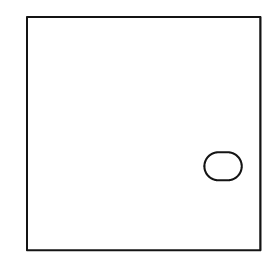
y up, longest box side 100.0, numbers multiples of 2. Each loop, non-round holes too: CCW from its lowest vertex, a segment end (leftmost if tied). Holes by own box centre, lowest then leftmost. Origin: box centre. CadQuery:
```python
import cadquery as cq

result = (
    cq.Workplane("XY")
    .moveTo(-50.0, -50.0)
    .lineTo(50.0, -50.0)
    .lineTo(50.0, 50.0)
    .lineTo(-50.0, 50.0)
    .close()
    .moveTo(32.0, -20.0)
    .lineTo(36.0, -20.0)
    .threePointArc((42.0, -14.0), (36.0, -8.0))
    .lineTo(32.0, -8.0)
    .threePointArc((26.0, -14.0), (32.0, -20.0))
    .close()
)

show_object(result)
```